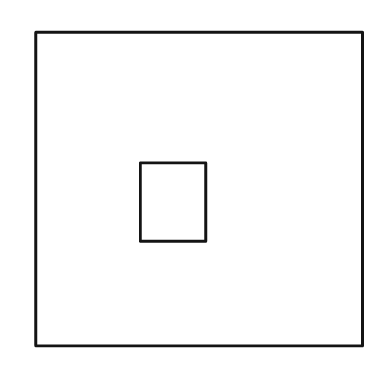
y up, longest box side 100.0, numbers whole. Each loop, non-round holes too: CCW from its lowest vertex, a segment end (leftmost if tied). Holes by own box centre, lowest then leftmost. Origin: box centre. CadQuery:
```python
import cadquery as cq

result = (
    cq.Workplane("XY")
    .moveTo(-50.0, -48.0)
    .lineTo(50.0, -48.0)
    .lineTo(50.0, 48.0)
    .lineTo(-50.0, 48.0)
    .close()
    .moveTo(-18.0, -16.0)
    .lineTo(2.0, -16.0)
    .lineTo(2.0, 8.0)
    .lineTo(-18.0, 8.0)
    .close()
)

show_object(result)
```